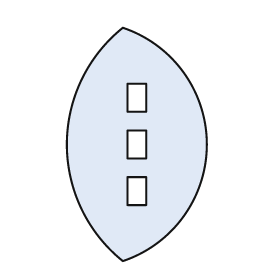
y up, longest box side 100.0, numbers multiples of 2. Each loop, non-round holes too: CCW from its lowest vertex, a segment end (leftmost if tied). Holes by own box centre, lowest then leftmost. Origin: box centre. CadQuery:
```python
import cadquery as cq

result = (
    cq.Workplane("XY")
    .moveTo(-6.0, -50.0)
    .threePointArc((30.0, 0.0), (-6.0, 50.0))
    .threePointArc((-30.0, 0.0), (-6.0, -50.0))
    .close()
    .moveTo(-4.0, -26.0)
    .lineTo(4.0, -26.0)
    .lineTo(4.0, -14.0)
    .lineTo(-4.0, -14.0)
    .close()
    .moveTo(-4.0, -6.0)
    .lineTo(4.0, -6.0)
    .lineTo(4.0, 6.0)
    .lineTo(-4.0, 6.0)
    .close()
    .moveTo(-4.0, 14.0)
    .lineTo(4.0, 14.0)
    .lineTo(4.0, 26.0)
    .lineTo(-4.0, 26.0)
    .close()
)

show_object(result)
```